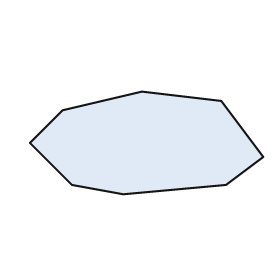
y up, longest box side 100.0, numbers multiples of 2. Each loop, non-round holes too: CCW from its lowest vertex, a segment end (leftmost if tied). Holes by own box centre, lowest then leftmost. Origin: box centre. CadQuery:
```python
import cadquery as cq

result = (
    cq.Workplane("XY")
    .moveTo(-10.0, -22.0)
    .lineTo(34.0, -18.0)
    .lineTo(50.0, -6.0)
    .lineTo(32.0, 18.0)
    .lineTo(-2.0, 22.0)
    .lineTo(-36.0, 14.0)
    .lineTo(-50.0, 0.0)
    .lineTo(-32.0, -18.0)
    .close()
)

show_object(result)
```